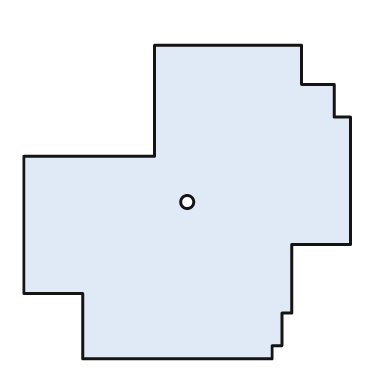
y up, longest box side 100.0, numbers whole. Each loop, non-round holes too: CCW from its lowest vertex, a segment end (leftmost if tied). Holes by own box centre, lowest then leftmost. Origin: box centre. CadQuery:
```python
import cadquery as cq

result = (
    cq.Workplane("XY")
    .moveTo(-32.0, -48.0)
    .lineTo(26.0, -48.0)
    .lineTo(26.0, -44.0)
    .lineTo(29.0, -44.0)
    .lineTo(29.0, -34.0)
    .lineTo(32.0, -34.0)
    .lineTo(32.0, -13.0)
    .lineTo(50.0, -13.0)
    .lineTo(50.0, 26.0)
    .lineTo(45.0, 26.0)
    .lineTo(45.0, 36.0)
    .lineTo(35.0, 36.0)
    .lineTo(35.0, 48.0)
    .lineTo(-10.0, 48.0)
    .lineTo(-10.0, 14.0)
    .lineTo(-50.0, 14.0)
    .lineTo(-50.0, -28.0)
    .lineTo(-32.0, -28.0)
    .close()
    .moveTo(0.0, 0.0)
    .circle(2.0)
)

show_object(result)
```